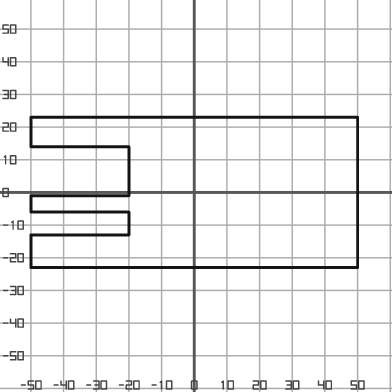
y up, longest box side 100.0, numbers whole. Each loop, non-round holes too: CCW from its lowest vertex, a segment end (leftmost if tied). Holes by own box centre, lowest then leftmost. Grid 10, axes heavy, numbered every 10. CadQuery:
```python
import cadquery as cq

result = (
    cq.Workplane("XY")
    .moveTo(-50.0, -23.0)
    .lineTo(50.0, -23.0)
    .lineTo(50.0, 23.0)
    .lineTo(-50.0, 23.0)
    .lineTo(-50.0, 14.0)
    .lineTo(-20.0, 14.0)
    .lineTo(-20.0, -1.0)
    .lineTo(-50.0, -1.0)
    .lineTo(-50.0, -6.0)
    .lineTo(-20.0, -6.0)
    .lineTo(-20.0, -13.0)
    .lineTo(-50.0, -13.0)
    .close()
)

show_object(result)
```